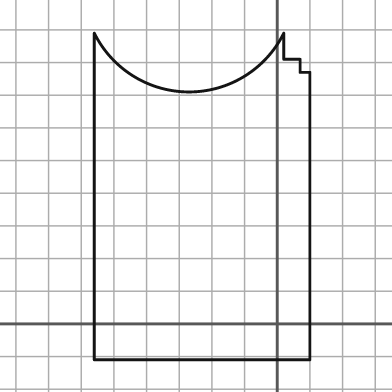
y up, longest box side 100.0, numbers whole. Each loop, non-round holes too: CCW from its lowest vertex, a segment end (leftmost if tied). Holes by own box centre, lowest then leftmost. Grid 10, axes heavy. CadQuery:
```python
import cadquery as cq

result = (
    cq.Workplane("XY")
    .moveTo(-56.0, -11.0)
    .lineTo(10.0, -11.0)
    .lineTo(10.0, 77.0)
    .lineTo(7.0, 77.0)
    .lineTo(7.0, 81.0)
    .lineTo(2.0, 81.0)
    .lineTo(2.0, 89.0)
    .threePointArc((-27.0, 71.0), (-56.0, 89.0))
    .close()
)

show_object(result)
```